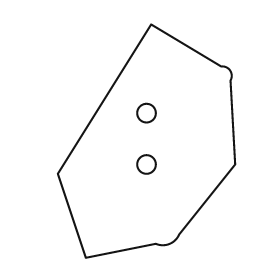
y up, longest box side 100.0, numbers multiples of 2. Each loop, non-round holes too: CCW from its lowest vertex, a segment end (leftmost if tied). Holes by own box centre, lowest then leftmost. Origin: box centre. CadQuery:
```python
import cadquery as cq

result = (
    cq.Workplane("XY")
    .moveTo(-26.0, -50.0)
    .lineTo(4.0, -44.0)
    .threePointArc((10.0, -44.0), (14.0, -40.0))
    .lineTo(38.0, -10.0)
    .lineTo(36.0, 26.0)
    .threePointArc((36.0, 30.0), (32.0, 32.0))
    .lineTo(2.0, 50.0)
    .lineTo(-38.0, -14.0)
    .close()
    .moveTo(0.0, -10.0)
    .circle(4.0)
    .moveTo(0.0, 12.0)
    .circle(4.0)
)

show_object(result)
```